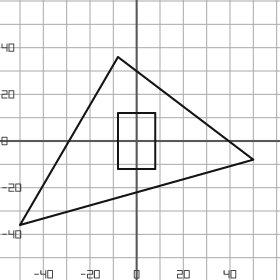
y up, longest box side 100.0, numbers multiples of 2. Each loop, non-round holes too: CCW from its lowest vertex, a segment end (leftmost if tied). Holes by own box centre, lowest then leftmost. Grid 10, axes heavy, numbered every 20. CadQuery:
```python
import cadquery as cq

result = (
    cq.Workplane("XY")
    .moveTo(-50.0, -36.0)
    .lineTo(50.0, -8.0)
    .lineTo(-8.0, 36.0)
    .close()
    .moveTo(-8.0, -12.0)
    .lineTo(8.0, -12.0)
    .lineTo(8.0, 12.0)
    .lineTo(-8.0, 12.0)
    .close()
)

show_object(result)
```